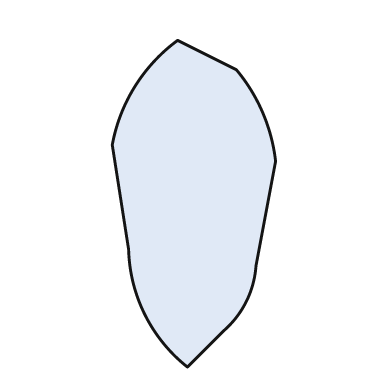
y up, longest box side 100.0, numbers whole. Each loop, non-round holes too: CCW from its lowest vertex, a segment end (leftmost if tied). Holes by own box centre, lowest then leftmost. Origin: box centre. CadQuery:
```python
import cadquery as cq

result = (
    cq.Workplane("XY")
    .moveTo(-2.0, -50.0)
    .lineTo(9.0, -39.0)
    .threePointArc((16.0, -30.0), (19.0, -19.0))
    .lineTo(25.0, 13.0)
    .threePointArc((21.0, 28.0), (13.0, 41.0))
    .lineTo(-5.0, 50.0)
    .threePointArc((-18.0, 36.0), (-25.0, 18.0))
    .lineTo(-20.0, -14.0)
    .threePointArc((-15.0, -34.0), (-2.0, -50.0))
    .close()
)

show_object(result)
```